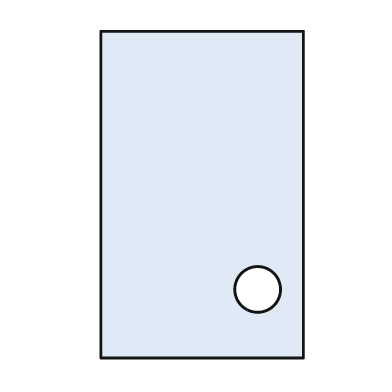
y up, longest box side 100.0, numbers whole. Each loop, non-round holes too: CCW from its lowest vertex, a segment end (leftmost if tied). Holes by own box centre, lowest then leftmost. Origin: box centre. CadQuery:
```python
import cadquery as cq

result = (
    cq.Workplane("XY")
    .moveTo(-31.0, -50.0)
    .lineTo(31.0, -50.0)
    .lineTo(31.0, 50.0)
    .lineTo(-31.0, 50.0)
    .close()
    .moveTo(17.0, -29.0)
    .circle(7.0)
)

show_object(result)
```